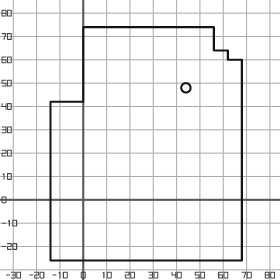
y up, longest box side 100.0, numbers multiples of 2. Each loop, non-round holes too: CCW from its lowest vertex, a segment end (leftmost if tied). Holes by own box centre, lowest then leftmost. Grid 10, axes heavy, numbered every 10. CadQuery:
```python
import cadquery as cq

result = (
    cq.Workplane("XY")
    .moveTo(-14.0, -26.0)
    .lineTo(68.0, -26.0)
    .lineTo(68.0, 60.0)
    .lineTo(62.0, 60.0)
    .lineTo(62.0, 64.0)
    .lineTo(56.0, 64.0)
    .lineTo(56.0, 74.0)
    .lineTo(0.0, 74.0)
    .lineTo(0.0, 42.0)
    .lineTo(-14.0, 42.0)
    .close()
    .moveTo(44.0, 48.0)
    .circle(2.0)
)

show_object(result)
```